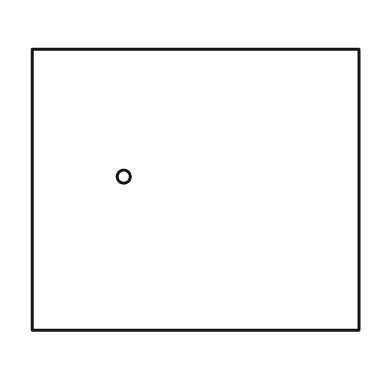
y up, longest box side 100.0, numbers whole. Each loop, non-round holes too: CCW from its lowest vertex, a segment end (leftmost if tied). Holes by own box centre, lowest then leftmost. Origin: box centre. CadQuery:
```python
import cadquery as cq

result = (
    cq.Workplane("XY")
    .moveTo(-50.0, -43.0)
    .lineTo(50.0, -43.0)
    .lineTo(50.0, 43.0)
    .lineTo(-50.0, 43.0)
    .close()
    .moveTo(-22.0, 4.0)
    .circle(2.0)
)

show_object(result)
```